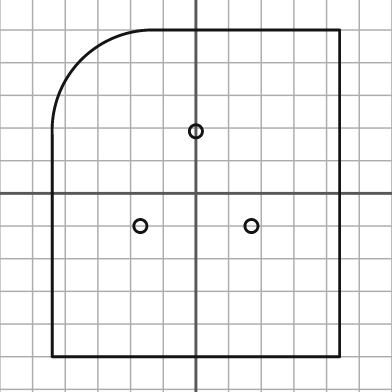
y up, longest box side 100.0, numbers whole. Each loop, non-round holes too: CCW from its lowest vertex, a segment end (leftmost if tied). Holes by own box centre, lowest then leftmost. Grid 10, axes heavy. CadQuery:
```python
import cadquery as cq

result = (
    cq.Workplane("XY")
    .moveTo(-44.0, -50.0)
    .lineTo(44.0, -50.0)
    .lineTo(44.0, 50.0)
    .lineTo(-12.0, 50.0)
    .threePointArc((-35.0, 41.0), (-44.0, 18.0))
    .close()
    .moveTo(-17.0, -10.0)
    .circle(2.0)
    .moveTo(17.0, -10.0)
    .circle(2.0)
    .moveTo(0.0, 19.0)
    .circle(2.0)
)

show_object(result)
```